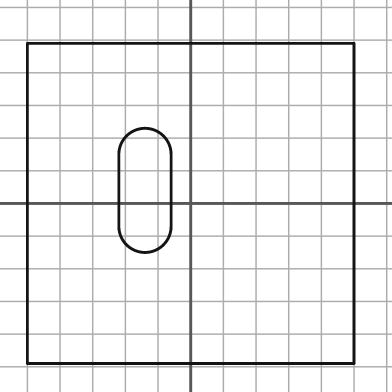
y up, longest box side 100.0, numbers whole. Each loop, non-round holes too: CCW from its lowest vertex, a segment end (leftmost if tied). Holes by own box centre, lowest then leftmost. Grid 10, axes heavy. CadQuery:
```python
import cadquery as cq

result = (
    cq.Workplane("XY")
    .moveTo(-50.0, -49.0)
    .lineTo(50.0, -49.0)
    .lineTo(50.0, 49.0)
    .lineTo(-50.0, 49.0)
    .close()
    .moveTo(-22.0, -7.0)
    .threePointArc((-14.0, -15.0), (-6.0, -7.0))
    .lineTo(-6.0, 15.0)
    .threePointArc((-14.0, 23.0), (-22.0, 15.0))
    .close()
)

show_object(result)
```